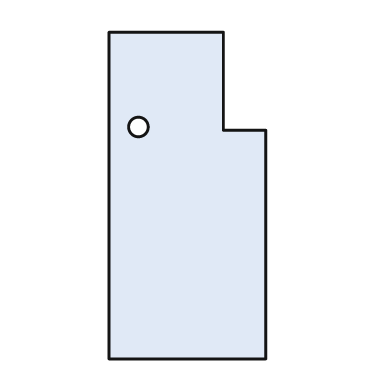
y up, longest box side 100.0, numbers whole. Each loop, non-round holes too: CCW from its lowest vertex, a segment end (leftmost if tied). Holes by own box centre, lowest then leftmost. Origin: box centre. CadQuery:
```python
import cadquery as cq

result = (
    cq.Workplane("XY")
    .moveTo(-24.0, -50.0)
    .lineTo(24.0, -50.0)
    .lineTo(24.0, 20.0)
    .lineTo(11.0, 20.0)
    .lineTo(11.0, 50.0)
    .lineTo(-24.0, 50.0)
    .close()
    .moveTo(-15.0, 21.0)
    .circle(3.0)
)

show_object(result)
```